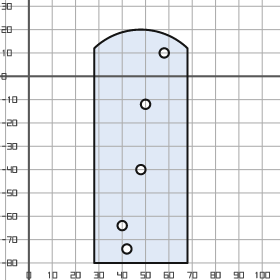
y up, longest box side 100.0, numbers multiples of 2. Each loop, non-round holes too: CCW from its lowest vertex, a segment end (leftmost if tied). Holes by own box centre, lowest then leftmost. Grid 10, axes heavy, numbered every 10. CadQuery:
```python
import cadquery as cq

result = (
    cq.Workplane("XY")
    .moveTo(28.0, -80.0)
    .lineTo(68.0, -80.0)
    .lineTo(68.0, 12.0)
    .threePointArc((48.0, 20.0), (28.0, 12.0))
    .close()
    .moveTo(42.0, -74.0)
    .circle(2.0)
    .moveTo(40.0, -64.0)
    .circle(2.0)
    .moveTo(48.0, -40.0)
    .circle(2.0)
    .moveTo(50.0, -12.0)
    .circle(2.0)
    .moveTo(58.0, 10.0)
    .circle(2.0)
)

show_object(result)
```